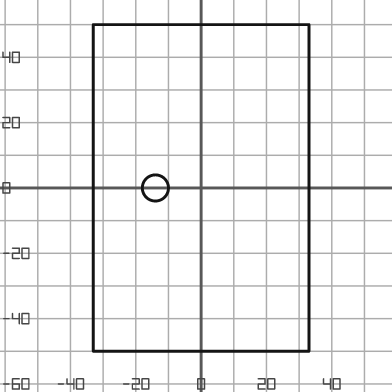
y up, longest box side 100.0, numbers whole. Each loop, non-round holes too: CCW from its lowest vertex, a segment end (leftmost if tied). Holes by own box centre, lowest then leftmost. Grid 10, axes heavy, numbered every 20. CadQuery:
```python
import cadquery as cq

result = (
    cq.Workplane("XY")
    .moveTo(-33.0, -50.0)
    .lineTo(33.0, -50.0)
    .lineTo(33.0, 50.0)
    .lineTo(-33.0, 50.0)
    .close()
    .moveTo(-14.0, 0.0)
    .circle(4.0)
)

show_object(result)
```